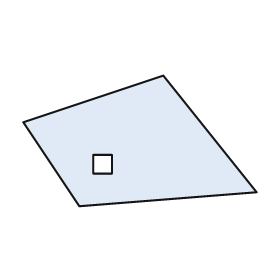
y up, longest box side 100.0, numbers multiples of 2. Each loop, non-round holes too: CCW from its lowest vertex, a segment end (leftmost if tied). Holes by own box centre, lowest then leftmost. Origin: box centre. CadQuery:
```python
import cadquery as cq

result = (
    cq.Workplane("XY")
    .moveTo(-26.0, -28.0)
    .lineTo(50.0, -22.0)
    .lineTo(10.0, 28.0)
    .lineTo(-50.0, 8.0)
    .close()
    .moveTo(-20.0, -14.0)
    .lineTo(-12.0, -14.0)
    .lineTo(-12.0, -6.0)
    .lineTo(-20.0, -6.0)
    .close()
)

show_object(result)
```